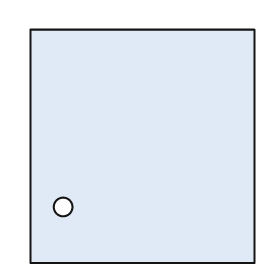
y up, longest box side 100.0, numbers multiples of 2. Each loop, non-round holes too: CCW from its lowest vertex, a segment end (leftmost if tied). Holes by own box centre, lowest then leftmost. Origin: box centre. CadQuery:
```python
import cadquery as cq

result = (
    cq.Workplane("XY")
    .moveTo(-48.0, -50.0)
    .lineTo(48.0, -50.0)
    .lineTo(48.0, 50.0)
    .lineTo(-48.0, 50.0)
    .close()
    .moveTo(-34.0, -26.0)
    .circle(4.0)
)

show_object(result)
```